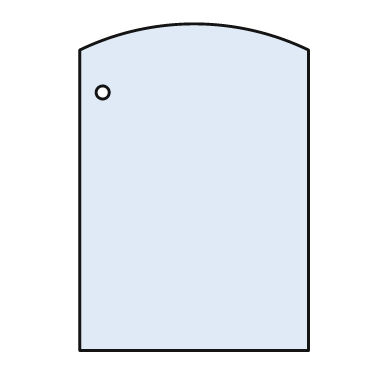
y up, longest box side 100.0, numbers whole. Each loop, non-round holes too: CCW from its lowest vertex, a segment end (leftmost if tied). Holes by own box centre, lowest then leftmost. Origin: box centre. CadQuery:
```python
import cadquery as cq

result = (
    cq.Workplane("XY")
    .moveTo(-35.0, -50.0)
    .lineTo(35.0, -50.0)
    .lineTo(35.0, 42.0)
    .threePointArc((0.0, 50.0), (-35.0, 42.0))
    .close()
    .moveTo(-28.0, 29.0)
    .circle(2.0)
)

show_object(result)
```